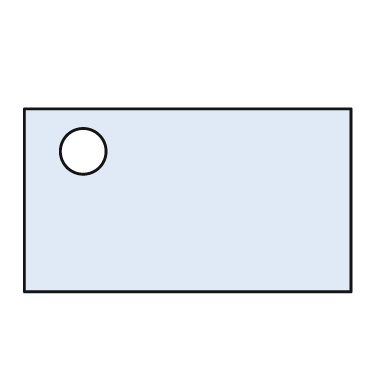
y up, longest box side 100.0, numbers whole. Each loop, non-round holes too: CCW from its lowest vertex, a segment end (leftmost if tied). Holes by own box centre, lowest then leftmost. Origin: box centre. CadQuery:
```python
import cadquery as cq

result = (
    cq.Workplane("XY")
    .moveTo(-50.0, -28.0)
    .lineTo(50.0, -28.0)
    .lineTo(50.0, 28.0)
    .lineTo(-50.0, 28.0)
    .close()
    .moveTo(-32.0, 15.0)
    .circle(7.0)
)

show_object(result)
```